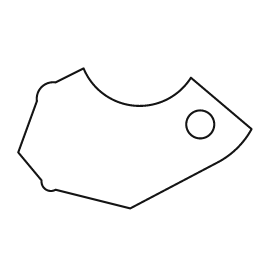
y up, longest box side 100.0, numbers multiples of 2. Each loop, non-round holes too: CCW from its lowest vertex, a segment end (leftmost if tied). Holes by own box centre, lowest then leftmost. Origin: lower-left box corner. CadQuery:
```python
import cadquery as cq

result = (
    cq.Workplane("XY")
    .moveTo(48.0, 0.0)
    .lineTo(86.0, 20.0)
    .threePointArc((94.0, 26.0), (100.0, 34.0))
    .lineTo(74.0, 56.0)
    .threePointArc((50.0, 44.0), (28.0, 60.0))
    .lineTo(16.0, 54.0)
    .threePointArc((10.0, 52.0), (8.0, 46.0))
    .lineTo(0.0, 24.0)
    .lineTo(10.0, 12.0)
    .threePointArc((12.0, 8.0), (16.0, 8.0))
    .close()
    .moveTo(78.0, 36.0)
    .circle(6.0)
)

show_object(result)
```